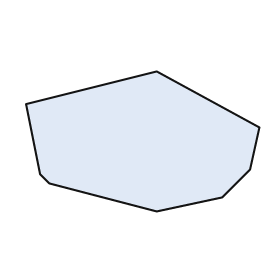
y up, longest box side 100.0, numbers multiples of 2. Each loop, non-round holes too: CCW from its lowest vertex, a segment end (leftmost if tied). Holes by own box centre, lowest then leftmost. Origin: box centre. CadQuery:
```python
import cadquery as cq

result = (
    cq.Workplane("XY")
    .moveTo(6.0, -30.0)
    .lineTo(34.0, -24.0)
    .lineTo(46.0, -12.0)
    .lineTo(50.0, 6.0)
    .lineTo(6.0, 30.0)
    .lineTo(-50.0, 16.0)
    .lineTo(-44.0, -14.0)
    .lineTo(-40.0, -18.0)
    .close()
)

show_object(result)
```